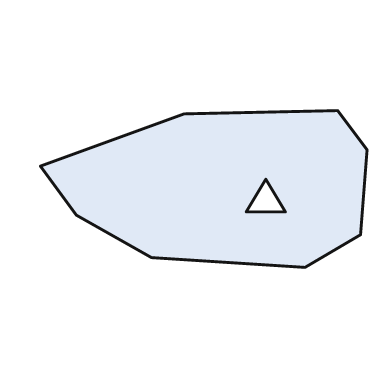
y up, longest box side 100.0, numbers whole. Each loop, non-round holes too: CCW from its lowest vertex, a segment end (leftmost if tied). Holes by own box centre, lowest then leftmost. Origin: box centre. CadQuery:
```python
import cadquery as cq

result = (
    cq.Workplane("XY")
    .moveTo(31.0, -24.0)
    .lineTo(48.0, -14.0)
    .lineTo(50.0, 12.0)
    .lineTo(41.0, 24.0)
    .lineTo(-6.0, 23.0)
    .lineTo(-50.0, 7.0)
    .lineTo(-39.0, -8.0)
    .lineTo(-16.0, -21.0)
    .close()
    .moveTo(13.0, -7.0)
    .lineTo(25.0, -7.0)
    .lineTo(19.0, 3.0)
    .close()
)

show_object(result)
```